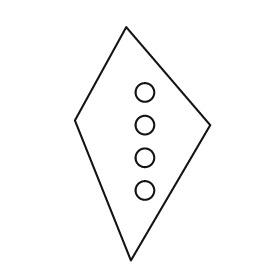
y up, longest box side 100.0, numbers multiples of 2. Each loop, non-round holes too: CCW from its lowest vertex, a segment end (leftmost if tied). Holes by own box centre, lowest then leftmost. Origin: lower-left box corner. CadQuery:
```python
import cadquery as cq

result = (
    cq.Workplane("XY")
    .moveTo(24.0, 0.0)
    .lineTo(58.0, 58.0)
    .lineTo(22.0, 100.0)
    .lineTo(0.0, 60.0)
    .close()
    .moveTo(30.0, 30.0)
    .circle(4.0)
    .moveTo(30.0, 44.0)
    .circle(4.0)
    .moveTo(30.0, 58.0)
    .circle(4.0)
    .moveTo(30.0, 72.0)
    .circle(4.0)
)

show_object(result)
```